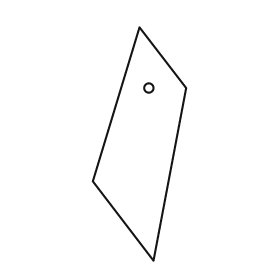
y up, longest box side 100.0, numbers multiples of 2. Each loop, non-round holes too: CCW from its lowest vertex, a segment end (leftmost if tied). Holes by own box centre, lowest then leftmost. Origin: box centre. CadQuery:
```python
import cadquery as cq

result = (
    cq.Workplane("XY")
    .moveTo(6.0, -50.0)
    .lineTo(20.0, 24.0)
    .lineTo(0.0, 50.0)
    .lineTo(-20.0, -16.0)
    .close()
    .moveTo(4.0, 24.0)
    .circle(2.0)
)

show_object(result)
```